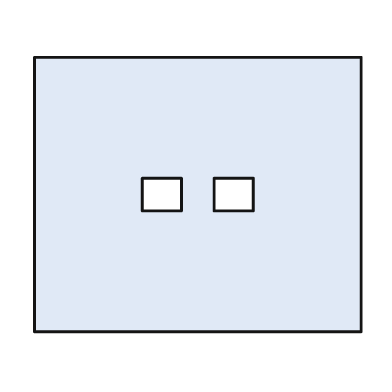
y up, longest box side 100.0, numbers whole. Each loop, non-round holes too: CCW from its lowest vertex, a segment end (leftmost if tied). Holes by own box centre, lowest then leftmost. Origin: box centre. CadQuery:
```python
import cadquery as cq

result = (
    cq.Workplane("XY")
    .moveTo(-50.0, -42.0)
    .lineTo(50.0, -42.0)
    .lineTo(50.0, 42.0)
    .lineTo(-50.0, 42.0)
    .close()
    .moveTo(-17.0, -5.0)
    .lineTo(-5.0, -5.0)
    .lineTo(-5.0, 5.0)
    .lineTo(-17.0, 5.0)
    .close()
    .moveTo(5.0, -5.0)
    .lineTo(17.0, -5.0)
    .lineTo(17.0, 5.0)
    .lineTo(5.0, 5.0)
    .close()
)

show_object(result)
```